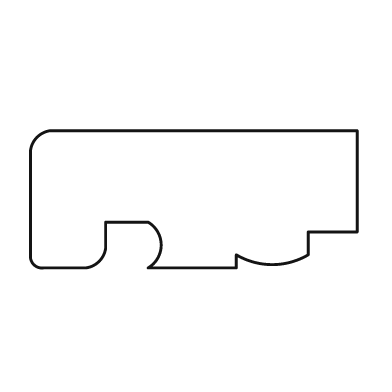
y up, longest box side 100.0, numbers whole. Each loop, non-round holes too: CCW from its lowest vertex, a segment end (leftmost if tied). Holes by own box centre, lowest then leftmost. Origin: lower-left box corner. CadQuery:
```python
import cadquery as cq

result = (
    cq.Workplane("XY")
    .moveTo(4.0, 0.0)
    .lineTo(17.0, 0.0)
    .threePointArc((21.0, 2.0), (23.0, 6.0))
    .lineTo(23.0, 14.0)
    .lineTo(36.0, 14.0)
    .threePointArc((40.0, 7.0), (36.0, 0.0))
    .lineTo(63.0, 0.0)
    .lineTo(63.0, 4.0)
    .threePointArc((74.0, 1.0), (85.0, 4.0))
    .lineTo(85.0, 11.0)
    .lineTo(100.0, 11.0)
    .lineTo(100.0, 42.0)
    .lineTo(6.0, 42.0)
    .threePointArc((2.0, 40.0), (0.0, 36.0))
    .lineTo(0.0, 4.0)
    .threePointArc((1.0, 1.0), (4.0, 0.0))
    .close()
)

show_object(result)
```